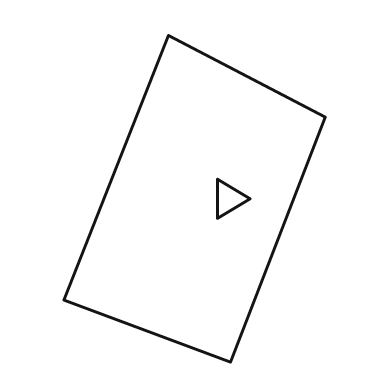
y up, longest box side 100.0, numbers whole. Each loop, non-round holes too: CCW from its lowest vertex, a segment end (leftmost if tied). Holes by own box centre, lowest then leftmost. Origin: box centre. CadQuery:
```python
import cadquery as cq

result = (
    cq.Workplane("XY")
    .moveTo(11.0, -50.0)
    .lineTo(40.0, 25.0)
    .lineTo(-8.0, 50.0)
    .lineTo(-40.0, -31.0)
    .close()
    .moveTo(7.0, -6.0)
    .lineTo(17.0, 0.0)
    .lineTo(7.0, 6.0)
    .close()
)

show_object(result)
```